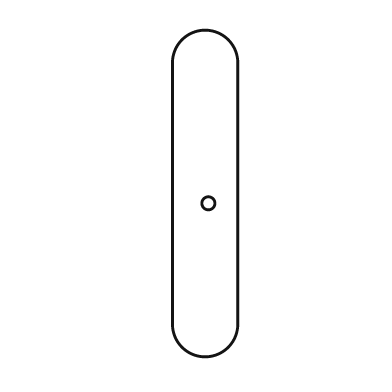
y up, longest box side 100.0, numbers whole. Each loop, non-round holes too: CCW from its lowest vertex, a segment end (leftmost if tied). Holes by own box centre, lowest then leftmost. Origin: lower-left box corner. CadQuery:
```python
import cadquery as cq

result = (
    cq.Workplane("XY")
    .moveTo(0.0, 10.0)
    .threePointArc((10.0, 0.0), (20.0, 10.0))
    .lineTo(20.0, 90.0)
    .threePointArc((10.0, 100.0), (0.0, 90.0))
    .close()
    .moveTo(11.0, 47.0)
    .circle(2.0)
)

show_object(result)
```